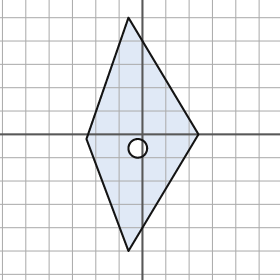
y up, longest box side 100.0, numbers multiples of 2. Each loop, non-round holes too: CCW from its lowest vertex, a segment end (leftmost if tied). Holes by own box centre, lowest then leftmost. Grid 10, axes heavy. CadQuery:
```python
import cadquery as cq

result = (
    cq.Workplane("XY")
    .moveTo(-6.0, -50.0)
    .lineTo(24.0, 0.0)
    .lineTo(-6.0, 50.0)
    .lineTo(-24.0, -2.0)
    .close()
    .moveTo(-2.0, -6.0)
    .circle(4.0)
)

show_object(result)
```